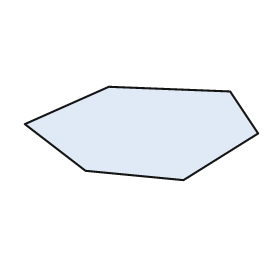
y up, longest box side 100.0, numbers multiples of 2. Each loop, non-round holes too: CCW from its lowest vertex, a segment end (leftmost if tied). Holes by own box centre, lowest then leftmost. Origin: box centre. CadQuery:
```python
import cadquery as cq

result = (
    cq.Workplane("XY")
    .moveTo(18.0, -20.0)
    .lineTo(50.0, 0.0)
    .lineTo(38.0, 18.0)
    .lineTo(-14.0, 20.0)
    .lineTo(-50.0, 4.0)
    .lineTo(-24.0, -16.0)
    .close()
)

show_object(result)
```